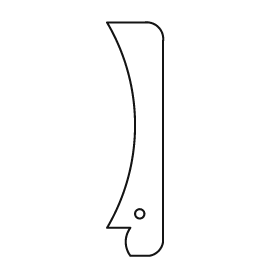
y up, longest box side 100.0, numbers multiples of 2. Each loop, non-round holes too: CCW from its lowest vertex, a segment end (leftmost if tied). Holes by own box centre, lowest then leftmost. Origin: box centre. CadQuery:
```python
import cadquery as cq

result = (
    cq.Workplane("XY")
    .moveTo(-2.0, -50.0)
    .lineTo(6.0, -50.0)
    .threePointArc((10.0, -48.0), (12.0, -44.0))
    .lineTo(12.0, 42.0)
    .threePointArc((10.0, 48.0), (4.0, 50.0))
    .lineTo(-12.0, 50.0)
    .threePointArc((0.0, 6.0), (-12.0, -38.0))
    .lineTo(-2.0, -38.0)
    .threePointArc((-4.0, -44.0), (-2.0, -50.0))
    .close()
    .moveTo(2.0, -32.0)
    .circle(2.0)
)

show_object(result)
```